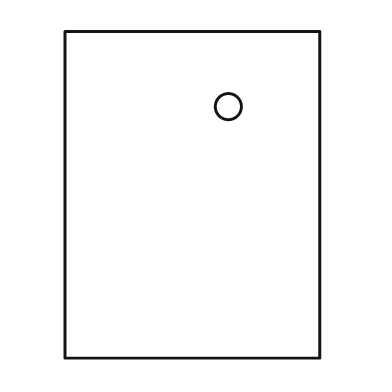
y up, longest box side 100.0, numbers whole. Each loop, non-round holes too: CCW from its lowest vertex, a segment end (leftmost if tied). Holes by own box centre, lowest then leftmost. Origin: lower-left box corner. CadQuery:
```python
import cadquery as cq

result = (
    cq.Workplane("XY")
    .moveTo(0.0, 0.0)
    .lineTo(78.0, 0.0)
    .lineTo(78.0, 100.0)
    .lineTo(0.0, 100.0)
    .close()
    .moveTo(50.0, 77.0)
    .circle(4.0)
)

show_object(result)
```